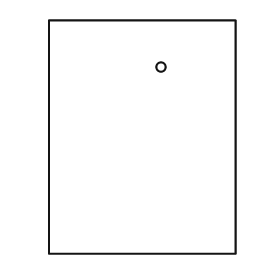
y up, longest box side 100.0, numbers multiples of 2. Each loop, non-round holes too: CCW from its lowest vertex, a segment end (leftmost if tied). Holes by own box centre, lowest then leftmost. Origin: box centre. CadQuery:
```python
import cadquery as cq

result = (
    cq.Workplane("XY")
    .moveTo(-40.0, -50.0)
    .lineTo(40.0, -50.0)
    .lineTo(40.0, 50.0)
    .lineTo(-40.0, 50.0)
    .close()
    .moveTo(8.0, 30.0)
    .circle(2.0)
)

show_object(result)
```